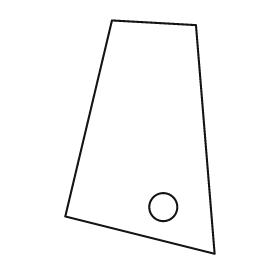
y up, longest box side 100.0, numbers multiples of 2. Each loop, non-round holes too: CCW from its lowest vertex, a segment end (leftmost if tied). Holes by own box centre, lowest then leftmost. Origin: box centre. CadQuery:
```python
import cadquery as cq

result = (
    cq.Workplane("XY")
    .moveTo(32.0, -50.0)
    .lineTo(24.0, 48.0)
    .lineTo(-12.0, 50.0)
    .lineTo(-32.0, -34.0)
    .close()
    .moveTo(10.0, -30.0)
    .circle(6.0)
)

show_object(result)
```